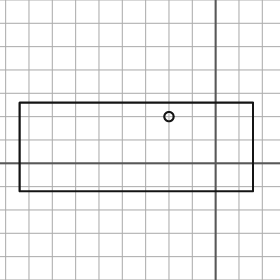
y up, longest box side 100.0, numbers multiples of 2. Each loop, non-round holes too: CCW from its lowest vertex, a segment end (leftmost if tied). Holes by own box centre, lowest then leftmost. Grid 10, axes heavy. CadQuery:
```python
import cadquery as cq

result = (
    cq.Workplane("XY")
    .moveTo(-84.0, -12.0)
    .lineTo(16.0, -12.0)
    .lineTo(16.0, 26.0)
    .lineTo(-84.0, 26.0)
    .close()
    .moveTo(-20.0, 20.0)
    .circle(2.0)
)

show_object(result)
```